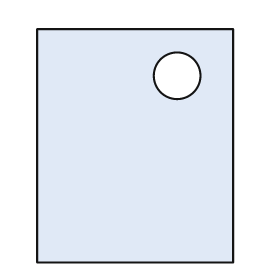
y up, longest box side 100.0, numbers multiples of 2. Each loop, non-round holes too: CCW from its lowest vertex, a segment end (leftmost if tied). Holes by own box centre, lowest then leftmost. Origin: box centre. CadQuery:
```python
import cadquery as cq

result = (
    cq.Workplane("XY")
    .moveTo(-42.0, -50.0)
    .lineTo(42.0, -50.0)
    .lineTo(42.0, 50.0)
    .lineTo(-42.0, 50.0)
    .close()
    .moveTo(18.0, 30.0)
    .circle(10.0)
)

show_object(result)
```